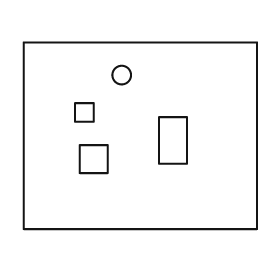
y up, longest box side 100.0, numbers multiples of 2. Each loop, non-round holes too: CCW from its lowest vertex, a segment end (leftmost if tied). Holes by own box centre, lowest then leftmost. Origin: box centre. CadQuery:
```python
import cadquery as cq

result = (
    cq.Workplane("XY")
    .moveTo(-50.0, -40.0)
    .lineTo(50.0, -40.0)
    .lineTo(50.0, 40.0)
    .lineTo(-50.0, 40.0)
    .close()
    .moveTo(-26.0, -16.0)
    .lineTo(-14.0, -16.0)
    .lineTo(-14.0, -4.0)
    .lineTo(-26.0, -4.0)
    .close()
    .moveTo(8.0, -12.0)
    .lineTo(20.0, -12.0)
    .lineTo(20.0, 8.0)
    .lineTo(8.0, 8.0)
    .close()
    .moveTo(-28.0, 6.0)
    .lineTo(-20.0, 6.0)
    .lineTo(-20.0, 14.0)
    .lineTo(-28.0, 14.0)
    .close()
    .moveTo(-8.0, 26.0)
    .circle(4.0)
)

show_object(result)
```